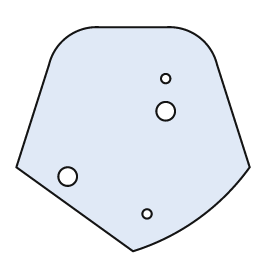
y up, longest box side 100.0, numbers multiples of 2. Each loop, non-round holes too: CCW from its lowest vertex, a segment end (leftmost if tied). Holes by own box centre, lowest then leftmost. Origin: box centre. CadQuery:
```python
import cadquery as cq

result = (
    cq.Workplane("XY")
    .moveTo(0.0, -48.0)
    .threePointArc((28.0, -34.0), (50.0, -12.0))
    .lineTo(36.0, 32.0)
    .threePointArc((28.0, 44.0), (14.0, 48.0))
    .lineTo(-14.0, 48.0)
    .threePointArc((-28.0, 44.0), (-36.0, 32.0))
    .lineTo(-50.0, -12.0)
    .close()
    .moveTo(6.0, -32.0)
    .circle(2.0)
    .moveTo(-28.0, -16.0)
    .circle(4.0)
    .moveTo(14.0, 12.0)
    .circle(4.0)
    .moveTo(14.0, 26.0)
    .circle(2.0)
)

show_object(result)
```